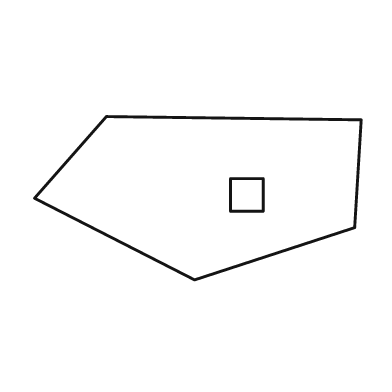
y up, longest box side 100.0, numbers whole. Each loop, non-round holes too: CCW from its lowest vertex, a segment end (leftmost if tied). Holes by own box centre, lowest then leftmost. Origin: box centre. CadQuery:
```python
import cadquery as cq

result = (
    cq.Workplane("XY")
    .moveTo(-1.0, -25.0)
    .lineTo(48.0, -9.0)
    .lineTo(50.0, 24.0)
    .lineTo(-28.0, 25.0)
    .lineTo(-50.0, 0.0)
    .close()
    .moveTo(10.0, -4.0)
    .lineTo(20.0, -4.0)
    .lineTo(20.0, 6.0)
    .lineTo(10.0, 6.0)
    .close()
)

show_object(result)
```